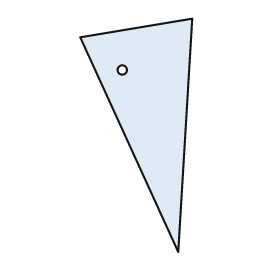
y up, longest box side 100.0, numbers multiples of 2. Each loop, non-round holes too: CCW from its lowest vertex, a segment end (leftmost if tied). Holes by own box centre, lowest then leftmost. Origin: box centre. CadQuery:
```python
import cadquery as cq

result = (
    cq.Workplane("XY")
    .moveTo(18.0, -50.0)
    .lineTo(24.0, 50.0)
    .lineTo(-24.0, 42.0)
    .close()
    .moveTo(-6.0, 28.0)
    .circle(2.0)
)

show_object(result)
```